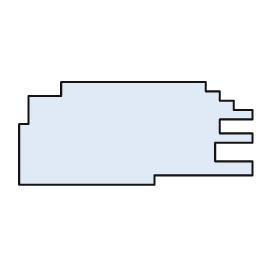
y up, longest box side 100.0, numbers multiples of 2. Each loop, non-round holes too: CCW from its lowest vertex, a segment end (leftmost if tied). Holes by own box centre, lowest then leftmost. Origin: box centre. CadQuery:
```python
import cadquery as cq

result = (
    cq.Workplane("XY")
    .moveTo(-50.0, -22.0)
    .lineTo(8.0, -22.0)
    .lineTo(8.0, -18.0)
    .lineTo(50.0, -18.0)
    .lineTo(50.0, -12.0)
    .lineTo(34.0, -12.0)
    .lineTo(34.0, -4.0)
    .lineTo(50.0, -4.0)
    .lineTo(50.0, 0.0)
    .lineTo(36.0, 0.0)
    .lineTo(36.0, 6.0)
    .lineTo(50.0, 6.0)
    .lineTo(50.0, 10.0)
    .lineTo(42.0, 10.0)
    .lineTo(42.0, 14.0)
    .lineTo(36.0, 14.0)
    .lineTo(36.0, 18.0)
    .lineTo(30.0, 18.0)
    .lineTo(30.0, 22.0)
    .lineTo(-32.0, 22.0)
    .lineTo(-32.0, 16.0)
    .lineTo(-46.0, 16.0)
    .lineTo(-46.0, 4.0)
    .lineTo(-50.0, 4.0)
    .close()
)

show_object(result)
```